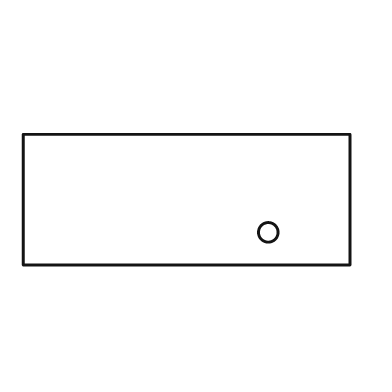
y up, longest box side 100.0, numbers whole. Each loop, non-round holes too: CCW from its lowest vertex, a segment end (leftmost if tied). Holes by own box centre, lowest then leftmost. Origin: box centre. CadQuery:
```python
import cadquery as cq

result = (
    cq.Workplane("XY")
    .moveTo(-50.0, -20.0)
    .lineTo(50.0, -20.0)
    .lineTo(50.0, 20.0)
    .lineTo(-50.0, 20.0)
    .close()
    .moveTo(25.0, -10.0)
    .circle(3.0)
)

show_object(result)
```